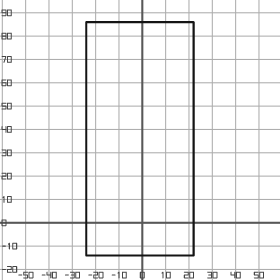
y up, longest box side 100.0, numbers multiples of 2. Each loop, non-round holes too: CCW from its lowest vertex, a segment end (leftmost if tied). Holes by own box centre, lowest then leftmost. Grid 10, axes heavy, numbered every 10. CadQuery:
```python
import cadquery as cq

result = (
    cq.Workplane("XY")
    .moveTo(-24.0, -14.0)
    .lineTo(22.0, -14.0)
    .lineTo(22.0, 86.0)
    .lineTo(-24.0, 86.0)
    .close()
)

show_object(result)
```